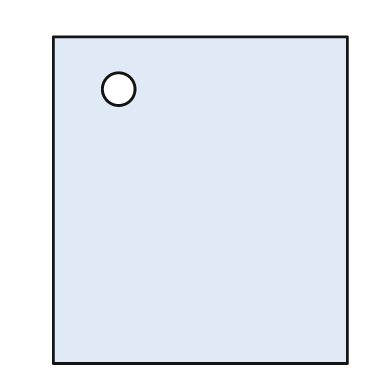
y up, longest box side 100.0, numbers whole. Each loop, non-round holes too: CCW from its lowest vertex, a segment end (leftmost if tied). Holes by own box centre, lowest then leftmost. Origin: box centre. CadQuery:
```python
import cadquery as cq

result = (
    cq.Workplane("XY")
    .moveTo(-45.0, -50.0)
    .lineTo(45.0, -50.0)
    .lineTo(45.0, 50.0)
    .lineTo(-45.0, 50.0)
    .close()
    .moveTo(-25.0, 34.0)
    .circle(5.0)
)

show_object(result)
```